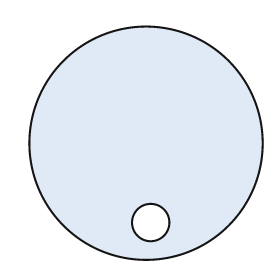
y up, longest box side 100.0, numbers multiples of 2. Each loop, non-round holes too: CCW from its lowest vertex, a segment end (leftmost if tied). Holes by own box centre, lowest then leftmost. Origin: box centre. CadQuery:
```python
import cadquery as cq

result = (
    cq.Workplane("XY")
    .moveTo(0.0, 0.0)
    .circle(50.0)
    .moveTo(2.0, -34.0)
    .circle(8.0)
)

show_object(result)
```